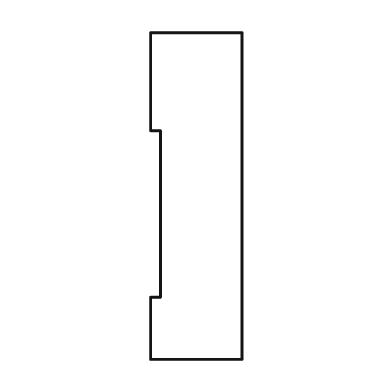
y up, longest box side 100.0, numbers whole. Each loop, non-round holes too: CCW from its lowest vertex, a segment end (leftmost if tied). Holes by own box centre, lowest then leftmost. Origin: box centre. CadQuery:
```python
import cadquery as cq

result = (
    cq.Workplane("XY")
    .moveTo(-14.0, -50.0)
    .lineTo(14.0, -50.0)
    .lineTo(14.0, 50.0)
    .lineTo(-14.0, 50.0)
    .lineTo(-14.0, 20.0)
    .lineTo(-11.0, 20.0)
    .lineTo(-11.0, -31.0)
    .lineTo(-14.0, -31.0)
    .close()
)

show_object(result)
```